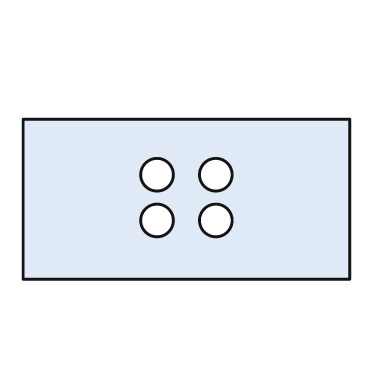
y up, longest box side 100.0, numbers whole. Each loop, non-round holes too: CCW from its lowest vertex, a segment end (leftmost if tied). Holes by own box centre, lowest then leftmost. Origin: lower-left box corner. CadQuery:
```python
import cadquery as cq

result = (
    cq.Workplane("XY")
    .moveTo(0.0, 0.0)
    .lineTo(100.0, 0.0)
    .lineTo(100.0, 49.0)
    .lineTo(0.0, 49.0)
    .close()
    .moveTo(41.0, 18.0)
    .circle(5.0)
    .moveTo(59.0, 18.0)
    .circle(5.0)
    .moveTo(41.0, 32.0)
    .circle(5.0)
    .moveTo(59.0, 32.0)
    .circle(5.0)
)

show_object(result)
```